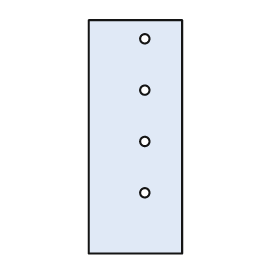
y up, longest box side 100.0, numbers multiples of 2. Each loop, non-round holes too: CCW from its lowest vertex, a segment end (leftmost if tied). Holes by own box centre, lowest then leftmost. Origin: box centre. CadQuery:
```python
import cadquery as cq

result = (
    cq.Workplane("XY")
    .moveTo(-20.0, -50.0)
    .lineTo(20.0, -50.0)
    .lineTo(20.0, 50.0)
    .lineTo(-20.0, 50.0)
    .close()
    .moveTo(4.0, -24.0)
    .circle(2.0)
    .moveTo(4.0, -2.0)
    .circle(2.0)
    .moveTo(4.0, 20.0)
    .circle(2.0)
    .moveTo(4.0, 42.0)
    .circle(2.0)
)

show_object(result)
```